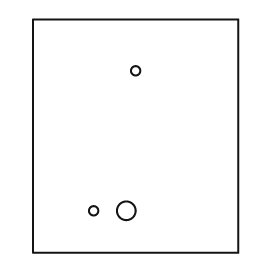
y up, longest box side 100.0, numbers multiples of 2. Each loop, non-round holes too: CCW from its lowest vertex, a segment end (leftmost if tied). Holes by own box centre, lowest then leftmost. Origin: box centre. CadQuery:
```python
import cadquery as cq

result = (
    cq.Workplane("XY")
    .moveTo(-44.0, -50.0)
    .lineTo(44.0, -50.0)
    .lineTo(44.0, 50.0)
    .lineTo(-44.0, 50.0)
    .close()
    .moveTo(-18.0, -32.0)
    .circle(2.0)
    .moveTo(-4.0, -32.0)
    .circle(4.0)
    .moveTo(0.0, 28.0)
    .circle(2.0)
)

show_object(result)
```